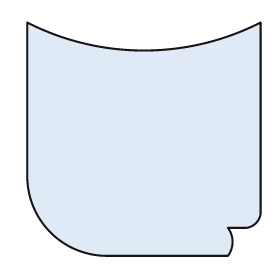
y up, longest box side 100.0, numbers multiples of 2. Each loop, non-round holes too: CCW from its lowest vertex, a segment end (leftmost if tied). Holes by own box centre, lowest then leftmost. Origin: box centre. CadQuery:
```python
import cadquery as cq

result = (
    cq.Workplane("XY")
    .moveTo(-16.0, -50.0)
    .lineTo(36.0, -50.0)
    .threePointArc((38.0, -44.0), (36.0, -38.0))
    .lineTo(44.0, -38.0)
    .threePointArc((48.0, -36.0), (50.0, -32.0))
    .lineTo(50.0, 50.0)
    .threePointArc((0.0, 38.0), (-50.0, 50.0))
    .lineTo(-50.0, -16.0)
    .threePointArc((-40.0, -40.0), (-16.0, -50.0))
    .close()
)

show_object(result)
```